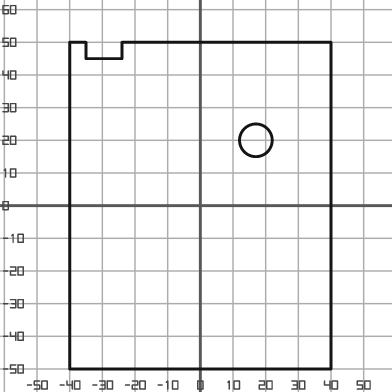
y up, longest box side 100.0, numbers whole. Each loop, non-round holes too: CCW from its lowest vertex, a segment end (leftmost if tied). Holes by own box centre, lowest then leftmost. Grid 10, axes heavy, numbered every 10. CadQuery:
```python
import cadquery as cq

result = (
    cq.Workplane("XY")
    .moveTo(-40.0, -50.0)
    .lineTo(40.0, -50.0)
    .lineTo(40.0, 50.0)
    .lineTo(-24.0, 50.0)
    .lineTo(-24.0, 45.0)
    .lineTo(-35.0, 45.0)
    .lineTo(-35.0, 50.0)
    .lineTo(-40.0, 50.0)
    .close()
    .moveTo(17.0, 20.0)
    .circle(5.0)
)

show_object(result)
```